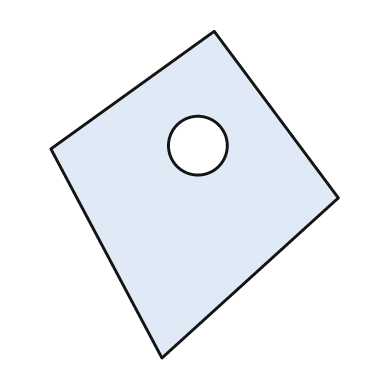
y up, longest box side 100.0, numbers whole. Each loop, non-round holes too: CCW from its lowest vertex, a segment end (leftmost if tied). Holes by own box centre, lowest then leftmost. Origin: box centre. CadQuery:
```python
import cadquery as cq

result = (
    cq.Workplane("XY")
    .moveTo(-10.0, -50.0)
    .lineTo(44.0, -1.0)
    .lineTo(6.0, 50.0)
    .lineTo(-44.0, 14.0)
    .close()
    .moveTo(1.0, 15.0)
    .circle(9.0)
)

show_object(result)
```